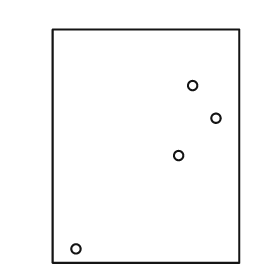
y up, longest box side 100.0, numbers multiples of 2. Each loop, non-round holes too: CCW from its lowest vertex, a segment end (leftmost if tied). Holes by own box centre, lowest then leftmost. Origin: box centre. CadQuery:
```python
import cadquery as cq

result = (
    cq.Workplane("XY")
    .moveTo(-40.0, -50.0)
    .lineTo(40.0, -50.0)
    .lineTo(40.0, 50.0)
    .lineTo(-40.0, 50.0)
    .close()
    .moveTo(-30.0, -44.0)
    .circle(2.0)
    .moveTo(14.0, -4.0)
    .circle(2.0)
    .moveTo(30.0, 12.0)
    .circle(2.0)
    .moveTo(20.0, 26.0)
    .circle(2.0)
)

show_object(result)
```